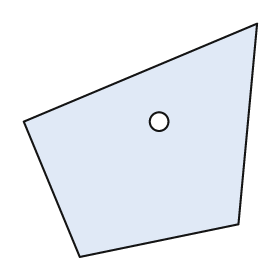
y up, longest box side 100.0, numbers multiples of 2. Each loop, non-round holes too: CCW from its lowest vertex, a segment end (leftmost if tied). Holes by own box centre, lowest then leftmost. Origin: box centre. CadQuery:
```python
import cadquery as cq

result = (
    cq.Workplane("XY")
    .moveTo(-26.0, -50.0)
    .lineTo(42.0, -36.0)
    .lineTo(50.0, 50.0)
    .lineTo(-50.0, 8.0)
    .close()
    .moveTo(8.0, 8.0)
    .circle(4.0)
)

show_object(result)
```